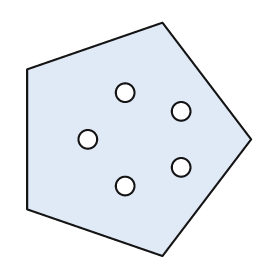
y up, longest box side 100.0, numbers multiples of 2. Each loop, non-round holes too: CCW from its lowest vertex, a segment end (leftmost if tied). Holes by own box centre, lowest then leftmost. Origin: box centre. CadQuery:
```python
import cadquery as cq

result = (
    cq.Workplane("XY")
    .moveTo(10.0, -50.0)
    .lineTo(48.0, 0.0)
    .lineTo(10.0, 50.0)
    .lineTo(-48.0, 30.0)
    .lineTo(-48.0, -30.0)
    .close()
    .moveTo(-6.0, -20.0)
    .circle(4.0)
    .moveTo(18.0, -12.0)
    .circle(4.0)
    .moveTo(-22.0, 0.0)
    .circle(4.0)
    .moveTo(18.0, 12.0)
    .circle(4.0)
    .moveTo(-6.0, 20.0)
    .circle(4.0)
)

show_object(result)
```